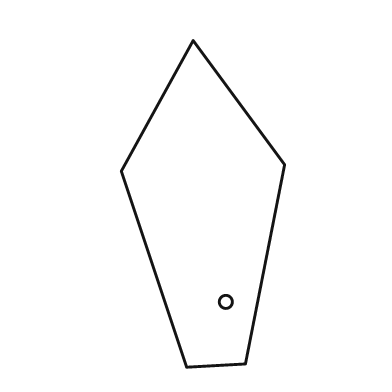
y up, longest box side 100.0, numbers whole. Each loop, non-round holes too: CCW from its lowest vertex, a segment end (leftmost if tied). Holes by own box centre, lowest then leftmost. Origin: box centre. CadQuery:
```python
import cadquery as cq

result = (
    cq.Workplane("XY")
    .moveTo(-5.0, -50.0)
    .lineTo(13.0, -49.0)
    .lineTo(25.0, 12.0)
    .lineTo(-3.0, 50.0)
    .lineTo(-25.0, 10.0)
    .close()
    .moveTo(7.0, -30.0)
    .circle(2.0)
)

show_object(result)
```